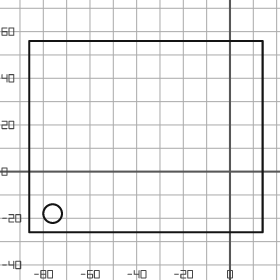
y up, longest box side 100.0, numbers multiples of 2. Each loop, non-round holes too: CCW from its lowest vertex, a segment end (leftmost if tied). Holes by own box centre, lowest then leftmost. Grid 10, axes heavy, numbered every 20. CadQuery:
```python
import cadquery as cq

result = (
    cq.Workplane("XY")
    .moveTo(-86.0, -26.0)
    .lineTo(14.0, -26.0)
    .lineTo(14.0, 56.0)
    .lineTo(-86.0, 56.0)
    .close()
    .moveTo(-76.0, -18.0)
    .circle(4.0)
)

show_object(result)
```